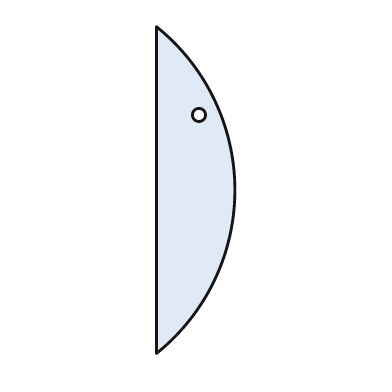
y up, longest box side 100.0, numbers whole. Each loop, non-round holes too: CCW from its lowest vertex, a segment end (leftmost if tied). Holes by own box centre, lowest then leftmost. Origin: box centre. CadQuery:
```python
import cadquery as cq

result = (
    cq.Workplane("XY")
    .moveTo(-12.0, -50.0)
    .threePointArc((12.0, 0.0), (-12.0, 50.0))
    .close()
    .moveTo(1.0, 23.0)
    .circle(2.0)
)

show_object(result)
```